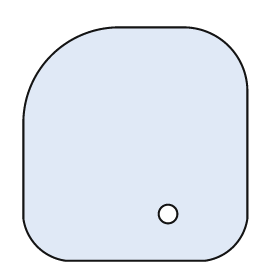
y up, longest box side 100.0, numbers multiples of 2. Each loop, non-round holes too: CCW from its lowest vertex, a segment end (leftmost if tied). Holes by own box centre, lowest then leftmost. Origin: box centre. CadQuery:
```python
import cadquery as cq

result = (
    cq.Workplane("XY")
    .moveTo(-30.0, -50.0)
    .lineTo(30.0, -50.0)
    .threePointArc((42.0, -44.0), (48.0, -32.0))
    .lineTo(48.0, 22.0)
    .threePointArc((40.0, 42.0), (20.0, 50.0))
    .lineTo(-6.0, 50.0)
    .threePointArc((-36.0, 38.0), (-48.0, 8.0))
    .lineTo(-48.0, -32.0)
    .threePointArc((-42.0, -44.0), (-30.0, -50.0))
    .close()
    .moveTo(14.0, -30.0)
    .circle(4.0)
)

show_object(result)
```